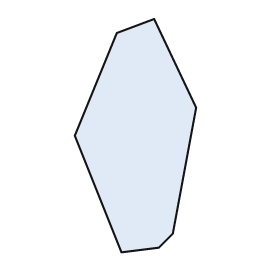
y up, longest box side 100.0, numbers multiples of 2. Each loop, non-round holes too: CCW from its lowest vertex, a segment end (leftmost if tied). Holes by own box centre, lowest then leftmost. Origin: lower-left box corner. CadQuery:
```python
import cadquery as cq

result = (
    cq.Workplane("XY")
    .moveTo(20.0, 0.0)
    .lineTo(36.0, 2.0)
    .lineTo(42.0, 8.0)
    .lineTo(52.0, 62.0)
    .lineTo(34.0, 100.0)
    .lineTo(18.0, 94.0)
    .lineTo(0.0, 50.0)
    .close()
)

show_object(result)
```